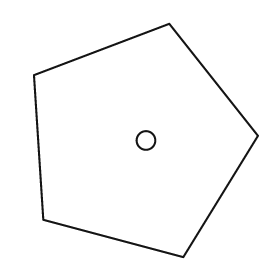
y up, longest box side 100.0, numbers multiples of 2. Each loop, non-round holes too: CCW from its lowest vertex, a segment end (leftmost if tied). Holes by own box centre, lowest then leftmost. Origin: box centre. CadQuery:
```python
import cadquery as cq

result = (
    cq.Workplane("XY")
    .moveTo(16.0, -50.0)
    .lineTo(48.0, 2.0)
    .lineTo(10.0, 50.0)
    .lineTo(-48.0, 28.0)
    .lineTo(-44.0, -34.0)
    .close()
    .moveTo(0.0, 0.0)
    .circle(4.0)
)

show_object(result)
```